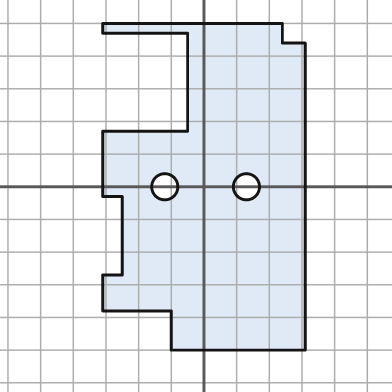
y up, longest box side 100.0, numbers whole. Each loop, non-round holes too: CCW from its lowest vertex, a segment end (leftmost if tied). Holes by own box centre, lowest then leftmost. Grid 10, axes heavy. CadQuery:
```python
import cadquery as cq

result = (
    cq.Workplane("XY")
    .moveTo(-10.0, -50.0)
    .lineTo(31.0, -50.0)
    .lineTo(31.0, 44.0)
    .lineTo(24.0, 44.0)
    .lineTo(24.0, 50.0)
    .lineTo(-31.0, 50.0)
    .lineTo(-31.0, 47.0)
    .lineTo(-5.0, 47.0)
    .lineTo(-5.0, 17.0)
    .lineTo(-31.0, 17.0)
    .lineTo(-31.0, -3.0)
    .lineTo(-25.0, -3.0)
    .lineTo(-25.0, -27.0)
    .lineTo(-31.0, -27.0)
    .lineTo(-31.0, -38.0)
    .lineTo(-10.0, -38.0)
    .close()
    .moveTo(-12.0, 0.0)
    .circle(4.0)
    .moveTo(13.0, 0.0)
    .circle(4.0)
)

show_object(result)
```